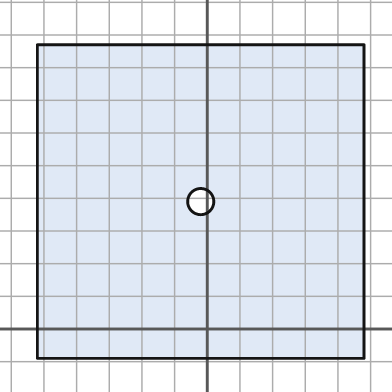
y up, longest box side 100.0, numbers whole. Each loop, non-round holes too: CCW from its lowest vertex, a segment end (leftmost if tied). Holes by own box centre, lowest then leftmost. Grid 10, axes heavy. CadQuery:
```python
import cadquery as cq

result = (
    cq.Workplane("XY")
    .moveTo(-52.0, -9.0)
    .lineTo(48.0, -9.0)
    .lineTo(48.0, 87.0)
    .lineTo(-52.0, 87.0)
    .close()
    .moveTo(-2.0, 39.0)
    .circle(4.0)
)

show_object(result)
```